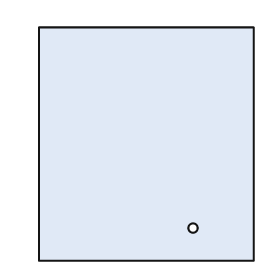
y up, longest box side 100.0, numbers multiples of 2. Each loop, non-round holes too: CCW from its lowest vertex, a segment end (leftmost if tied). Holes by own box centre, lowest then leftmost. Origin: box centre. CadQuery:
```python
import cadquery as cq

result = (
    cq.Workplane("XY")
    .moveTo(-46.0, -50.0)
    .lineTo(46.0, -50.0)
    .lineTo(46.0, 50.0)
    .lineTo(-46.0, 50.0)
    .close()
    .moveTo(20.0, -36.0)
    .circle(2.0)
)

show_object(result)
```